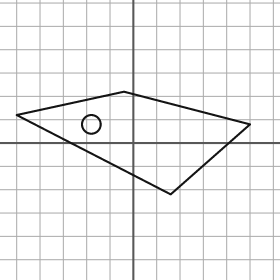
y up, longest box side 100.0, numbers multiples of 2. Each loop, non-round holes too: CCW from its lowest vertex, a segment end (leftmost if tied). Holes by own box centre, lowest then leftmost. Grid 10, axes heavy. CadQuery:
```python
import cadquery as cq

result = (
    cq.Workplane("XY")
    .moveTo(16.0, -22.0)
    .lineTo(50.0, 8.0)
    .lineTo(-4.0, 22.0)
    .lineTo(-50.0, 12.0)
    .close()
    .moveTo(-18.0, 8.0)
    .circle(4.0)
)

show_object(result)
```